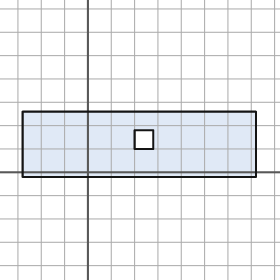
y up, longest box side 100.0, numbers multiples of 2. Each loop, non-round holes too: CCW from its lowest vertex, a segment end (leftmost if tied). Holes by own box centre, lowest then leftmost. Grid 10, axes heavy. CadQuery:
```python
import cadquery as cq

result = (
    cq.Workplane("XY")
    .moveTo(-28.0, -2.0)
    .lineTo(72.0, -2.0)
    .lineTo(72.0, 26.0)
    .lineTo(-28.0, 26.0)
    .close()
    .moveTo(20.0, 10.0)
    .lineTo(28.0, 10.0)
    .lineTo(28.0, 18.0)
    .lineTo(20.0, 18.0)
    .close()
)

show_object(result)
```